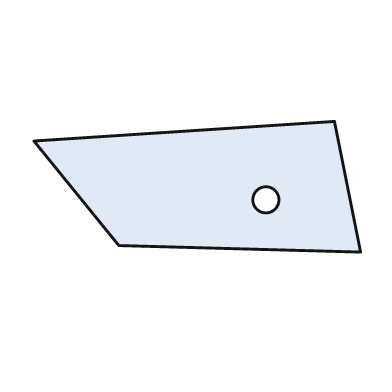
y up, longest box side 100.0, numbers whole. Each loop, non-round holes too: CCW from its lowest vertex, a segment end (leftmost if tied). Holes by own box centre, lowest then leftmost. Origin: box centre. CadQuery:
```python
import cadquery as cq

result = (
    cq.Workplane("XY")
    .moveTo(50.0, -20.0)
    .lineTo(42.0, 20.0)
    .lineTo(-50.0, 14.0)
    .lineTo(-24.0, -18.0)
    .close()
    .moveTo(21.0, -4.0)
    .circle(4.0)
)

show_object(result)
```